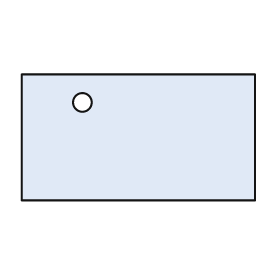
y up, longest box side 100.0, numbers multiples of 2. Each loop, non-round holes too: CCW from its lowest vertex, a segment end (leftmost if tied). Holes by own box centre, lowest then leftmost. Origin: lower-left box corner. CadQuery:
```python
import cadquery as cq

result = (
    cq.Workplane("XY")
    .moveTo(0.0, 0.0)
    .lineTo(100.0, 0.0)
    .lineTo(100.0, 54.0)
    .lineTo(0.0, 54.0)
    .close()
    .moveTo(26.0, 42.0)
    .circle(4.0)
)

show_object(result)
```